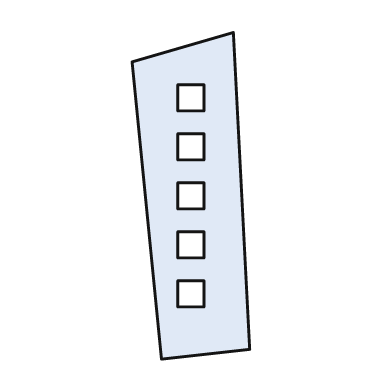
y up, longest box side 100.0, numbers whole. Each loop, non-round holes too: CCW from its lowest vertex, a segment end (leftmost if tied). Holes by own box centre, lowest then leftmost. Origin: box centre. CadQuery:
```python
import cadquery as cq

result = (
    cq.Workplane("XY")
    .moveTo(-9.0, -50.0)
    .lineTo(18.0, -47.0)
    .lineTo(13.0, 50.0)
    .lineTo(-18.0, 41.0)
    .close()
    .moveTo(-4.0, -34.0)
    .lineTo(4.0, -34.0)
    .lineTo(4.0, -26.0)
    .lineTo(-4.0, -26.0)
    .close()
    .moveTo(-4.0, -19.0)
    .lineTo(4.0, -19.0)
    .lineTo(4.0, -11.0)
    .lineTo(-4.0, -11.0)
    .close()
    .moveTo(-4.0, -4.0)
    .lineTo(4.0, -4.0)
    .lineTo(4.0, 4.0)
    .lineTo(-4.0, 4.0)
    .close()
    .moveTo(-4.0, 11.0)
    .lineTo(4.0, 11.0)
    .lineTo(4.0, 19.0)
    .lineTo(-4.0, 19.0)
    .close()
    .moveTo(-4.0, 26.0)
    .lineTo(4.0, 26.0)
    .lineTo(4.0, 34.0)
    .lineTo(-4.0, 34.0)
    .close()
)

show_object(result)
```